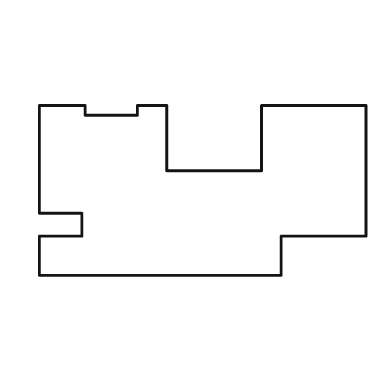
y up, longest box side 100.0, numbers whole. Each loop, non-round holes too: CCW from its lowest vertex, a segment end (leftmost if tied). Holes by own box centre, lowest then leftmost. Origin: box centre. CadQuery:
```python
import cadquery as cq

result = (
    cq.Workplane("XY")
    .moveTo(-50.0, -26.0)
    .lineTo(24.0, -26.0)
    .lineTo(24.0, -14.0)
    .lineTo(50.0, -14.0)
    .lineTo(50.0, 26.0)
    .lineTo(18.0, 26.0)
    .lineTo(18.0, 6.0)
    .lineTo(-11.0, 6.0)
    .lineTo(-11.0, 26.0)
    .lineTo(-20.0, 26.0)
    .lineTo(-20.0, 23.0)
    .lineTo(-36.0, 23.0)
    .lineTo(-36.0, 26.0)
    .lineTo(-50.0, 26.0)
    .lineTo(-50.0, -7.0)
    .lineTo(-37.0, -7.0)
    .lineTo(-37.0, -14.0)
    .lineTo(-50.0, -14.0)
    .close()
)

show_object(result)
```